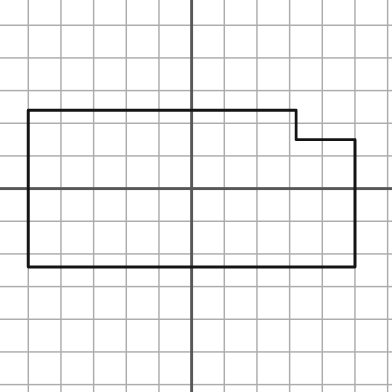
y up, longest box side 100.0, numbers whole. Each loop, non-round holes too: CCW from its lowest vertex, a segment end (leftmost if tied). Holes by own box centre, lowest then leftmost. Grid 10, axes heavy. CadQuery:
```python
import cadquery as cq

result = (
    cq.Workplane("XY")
    .moveTo(-50.0, -24.0)
    .lineTo(50.0, -24.0)
    .lineTo(50.0, 15.0)
    .lineTo(32.0, 15.0)
    .lineTo(32.0, 24.0)
    .lineTo(-50.0, 24.0)
    .close()
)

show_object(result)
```